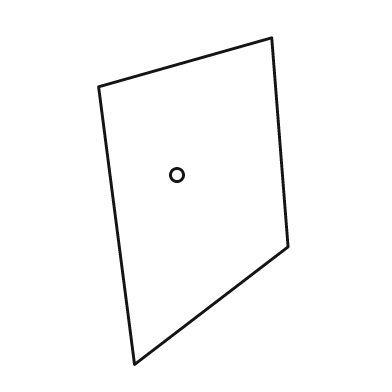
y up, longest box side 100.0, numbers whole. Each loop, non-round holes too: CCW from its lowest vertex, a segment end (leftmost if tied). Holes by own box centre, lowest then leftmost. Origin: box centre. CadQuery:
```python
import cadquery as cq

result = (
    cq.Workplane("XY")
    .moveTo(-18.0, -50.0)
    .lineTo(29.0, -14.0)
    .lineTo(24.0, 50.0)
    .lineTo(-29.0, 35.0)
    .close()
    .moveTo(-5.0, 8.0)
    .circle(2.0)
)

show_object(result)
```